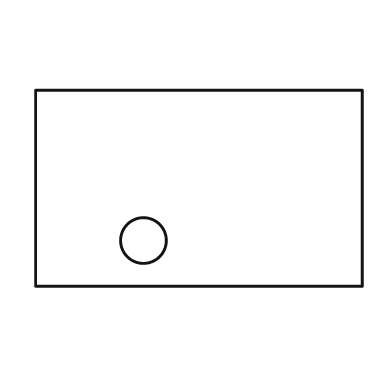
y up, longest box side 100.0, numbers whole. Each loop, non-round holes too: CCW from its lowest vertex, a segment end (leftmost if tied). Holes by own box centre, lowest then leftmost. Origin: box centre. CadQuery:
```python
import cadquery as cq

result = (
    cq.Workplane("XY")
    .moveTo(-50.0, -30.0)
    .lineTo(50.0, -30.0)
    .lineTo(50.0, 30.0)
    .lineTo(-50.0, 30.0)
    .close()
    .moveTo(-17.0, -16.0)
    .circle(7.0)
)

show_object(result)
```